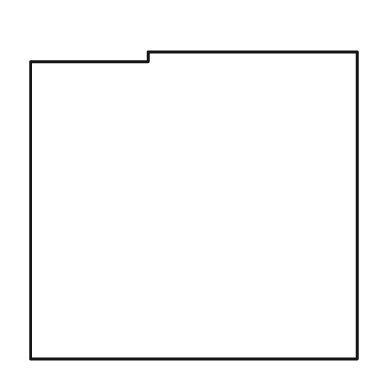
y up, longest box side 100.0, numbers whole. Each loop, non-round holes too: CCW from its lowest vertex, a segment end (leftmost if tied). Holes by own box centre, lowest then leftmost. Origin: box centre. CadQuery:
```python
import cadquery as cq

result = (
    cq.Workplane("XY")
    .moveTo(-50.0, -47.0)
    .lineTo(50.0, -47.0)
    .lineTo(50.0, 47.0)
    .lineTo(-14.0, 47.0)
    .lineTo(-14.0, 44.0)
    .lineTo(-50.0, 44.0)
    .close()
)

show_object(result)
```